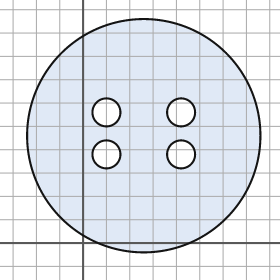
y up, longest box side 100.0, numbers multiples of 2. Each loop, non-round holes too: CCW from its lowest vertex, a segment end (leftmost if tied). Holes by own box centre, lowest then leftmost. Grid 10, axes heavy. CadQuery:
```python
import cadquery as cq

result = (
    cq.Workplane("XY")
    .moveTo(26.0, 46.0)
    .circle(50.0)
    .moveTo(10.0, 38.0)
    .circle(6.0)
    .moveTo(42.0, 38.0)
    .circle(6.0)
    .moveTo(10.0, 56.0)
    .circle(6.0)
    .moveTo(42.0, 56.0)
    .circle(6.0)
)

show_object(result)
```